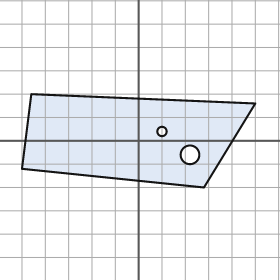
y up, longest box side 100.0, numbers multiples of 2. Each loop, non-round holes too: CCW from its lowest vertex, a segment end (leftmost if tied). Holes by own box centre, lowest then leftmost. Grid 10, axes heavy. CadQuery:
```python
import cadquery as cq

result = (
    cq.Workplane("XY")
    .moveTo(28.0, -20.0)
    .lineTo(50.0, 16.0)
    .lineTo(-46.0, 20.0)
    .lineTo(-50.0, -12.0)
    .close()
    .moveTo(22.0, -6.0)
    .circle(4.0)
    .moveTo(10.0, 4.0)
    .circle(2.0)
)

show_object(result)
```